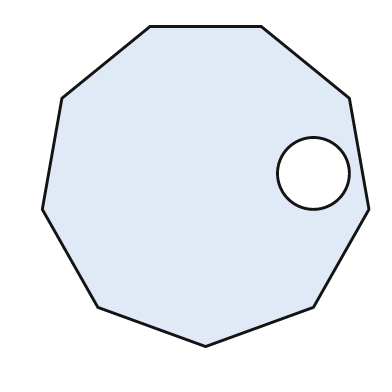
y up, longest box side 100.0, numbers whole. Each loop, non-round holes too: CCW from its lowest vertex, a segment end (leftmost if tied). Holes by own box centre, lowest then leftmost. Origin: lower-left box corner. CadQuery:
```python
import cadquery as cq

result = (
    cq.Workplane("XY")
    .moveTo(50.0, 0.0)
    .lineTo(83.0, 12.0)
    .lineTo(100.0, 42.0)
    .lineTo(94.0, 76.0)
    .lineTo(67.0, 98.0)
    .lineTo(33.0, 98.0)
    .lineTo(6.0, 76.0)
    .lineTo(0.0, 42.0)
    .lineTo(17.0, 12.0)
    .close()
    .moveTo(83.0, 53.0)
    .circle(11.0)
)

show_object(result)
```